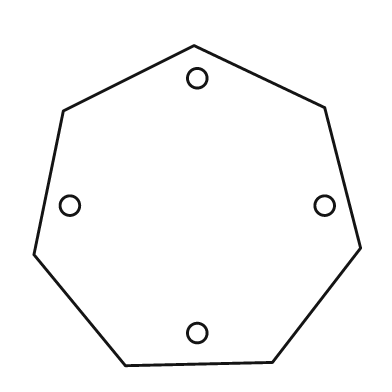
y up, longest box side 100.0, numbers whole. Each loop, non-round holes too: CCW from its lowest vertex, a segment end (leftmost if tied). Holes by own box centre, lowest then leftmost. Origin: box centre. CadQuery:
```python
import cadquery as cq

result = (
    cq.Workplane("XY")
    .moveTo(-22.0, -49.0)
    .lineTo(23.0, -48.0)
    .lineTo(50.0, -13.0)
    .lineTo(39.0, 30.0)
    .lineTo(-1.0, 49.0)
    .lineTo(-41.0, 29.0)
    .lineTo(-50.0, -15.0)
    .close()
    .moveTo(0.0, -39.0)
    .circle(3.0)
    .moveTo(-39.0, 0.0)
    .circle(3.0)
    .moveTo(39.0, 0.0)
    .circle(3.0)
    .moveTo(0.0, 39.0)
    .circle(3.0)
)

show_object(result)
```